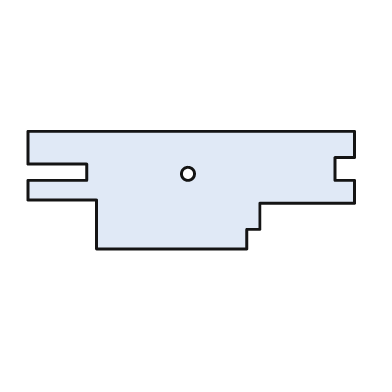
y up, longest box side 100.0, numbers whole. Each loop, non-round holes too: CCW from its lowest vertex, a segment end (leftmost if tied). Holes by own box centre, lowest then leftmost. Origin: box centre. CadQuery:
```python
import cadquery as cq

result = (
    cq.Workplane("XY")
    .moveTo(-29.0, -18.0)
    .lineTo(17.0, -18.0)
    .lineTo(17.0, -12.0)
    .lineTo(21.0, -12.0)
    .lineTo(21.0, -4.0)
    .lineTo(50.0, -4.0)
    .lineTo(50.0, 3.0)
    .lineTo(44.0, 3.0)
    .lineTo(44.0, 10.0)
    .lineTo(50.0, 10.0)
    .lineTo(50.0, 18.0)
    .lineTo(-50.0, 18.0)
    .lineTo(-50.0, 8.0)
    .lineTo(-32.0, 8.0)
    .lineTo(-32.0, 3.0)
    .lineTo(-50.0, 3.0)
    .lineTo(-50.0, -3.0)
    .lineTo(-29.0, -3.0)
    .close()
    .moveTo(-1.0, 5.0)
    .circle(2.0)
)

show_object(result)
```